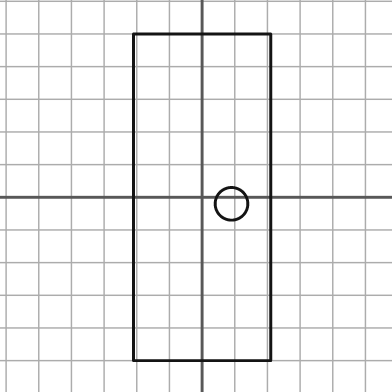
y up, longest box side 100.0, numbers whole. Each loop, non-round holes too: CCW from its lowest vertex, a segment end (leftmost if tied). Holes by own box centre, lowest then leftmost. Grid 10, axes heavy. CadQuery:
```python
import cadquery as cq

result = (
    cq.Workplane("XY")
    .moveTo(-21.0, -50.0)
    .lineTo(21.0, -50.0)
    .lineTo(21.0, 50.0)
    .lineTo(-21.0, 50.0)
    .close()
    .moveTo(9.0, -2.0)
    .circle(5.0)
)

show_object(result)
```